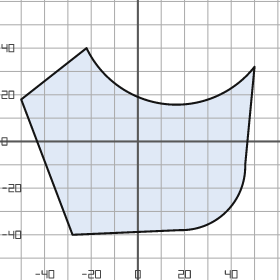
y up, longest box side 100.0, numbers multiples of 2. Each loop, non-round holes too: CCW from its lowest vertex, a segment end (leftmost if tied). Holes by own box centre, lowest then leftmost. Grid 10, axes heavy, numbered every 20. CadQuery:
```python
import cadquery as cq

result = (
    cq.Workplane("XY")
    .moveTo(-28.0, -40.0)
    .lineTo(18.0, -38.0)
    .threePointArc((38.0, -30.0), (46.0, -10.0))
    .lineTo(50.0, 32.0)
    .threePointArc((12.0, 16.0), (-22.0, 40.0))
    .lineTo(-50.0, 18.0)
    .close()
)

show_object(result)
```